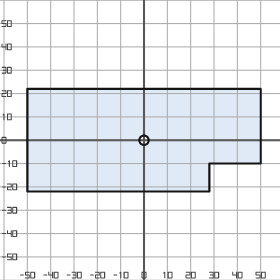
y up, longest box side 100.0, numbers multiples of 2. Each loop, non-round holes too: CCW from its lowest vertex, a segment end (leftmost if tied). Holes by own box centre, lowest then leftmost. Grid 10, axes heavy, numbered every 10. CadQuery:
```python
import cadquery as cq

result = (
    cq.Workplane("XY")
    .moveTo(-50.0, -22.0)
    .lineTo(28.0, -22.0)
    .lineTo(28.0, -10.0)
    .lineTo(50.0, -10.0)
    .lineTo(50.0, 22.0)
    .lineTo(-50.0, 22.0)
    .close()
    .moveTo(0.0, 0.0)
    .circle(2.0)
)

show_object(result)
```